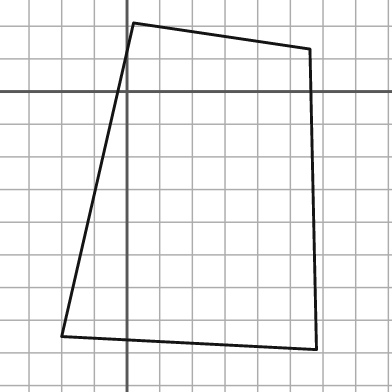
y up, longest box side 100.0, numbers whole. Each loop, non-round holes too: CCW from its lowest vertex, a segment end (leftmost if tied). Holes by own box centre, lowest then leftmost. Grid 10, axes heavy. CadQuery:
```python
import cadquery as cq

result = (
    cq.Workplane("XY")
    .moveTo(58.0, -79.0)
    .lineTo(56.0, 13.0)
    .lineTo(2.0, 21.0)
    .lineTo(-20.0, -75.0)
    .close()
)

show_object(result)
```